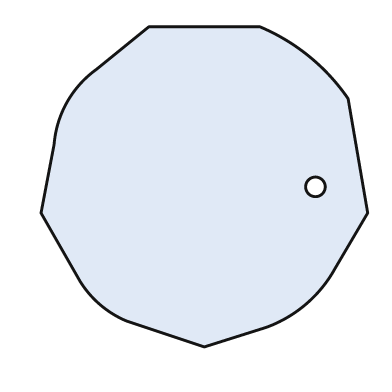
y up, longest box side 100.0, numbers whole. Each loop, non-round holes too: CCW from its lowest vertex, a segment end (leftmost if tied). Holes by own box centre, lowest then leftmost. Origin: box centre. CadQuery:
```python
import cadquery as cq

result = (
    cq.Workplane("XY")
    .moveTo(0.0, -49.0)
    .lineTo(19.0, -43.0)
    .threePointArc((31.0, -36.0), (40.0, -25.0))
    .lineTo(50.0, -8.0)
    .lineTo(44.0, 27.0)
    .threePointArc((32.0, 40.0), (17.0, 49.0))
    .lineTo(-17.0, 49.0)
    .lineTo(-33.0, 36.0)
    .threePointArc((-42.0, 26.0), (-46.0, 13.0))
    .lineTo(-50.0, -8.0)
    .lineTo(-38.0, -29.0)
    .threePointArc((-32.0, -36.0), (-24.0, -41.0))
    .close()
    .moveTo(34.0, 0.0)
    .circle(3.0)
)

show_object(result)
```